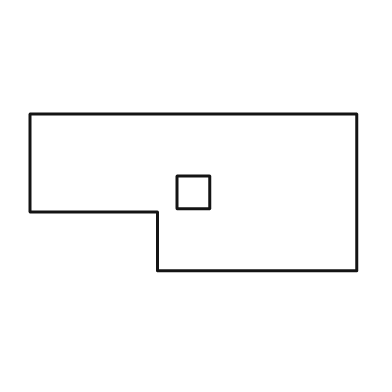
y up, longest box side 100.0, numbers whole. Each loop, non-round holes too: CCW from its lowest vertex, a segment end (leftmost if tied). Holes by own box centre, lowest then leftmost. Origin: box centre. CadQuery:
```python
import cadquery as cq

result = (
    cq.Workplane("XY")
    .moveTo(-11.0, -24.0)
    .lineTo(50.0, -24.0)
    .lineTo(50.0, 24.0)
    .lineTo(-50.0, 24.0)
    .lineTo(-50.0, -6.0)
    .lineTo(-11.0, -6.0)
    .close()
    .moveTo(-5.0, -5.0)
    .lineTo(5.0, -5.0)
    .lineTo(5.0, 5.0)
    .lineTo(-5.0, 5.0)
    .close()
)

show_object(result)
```